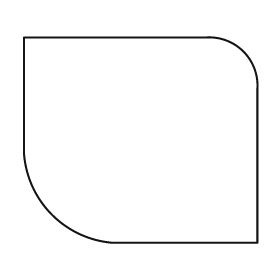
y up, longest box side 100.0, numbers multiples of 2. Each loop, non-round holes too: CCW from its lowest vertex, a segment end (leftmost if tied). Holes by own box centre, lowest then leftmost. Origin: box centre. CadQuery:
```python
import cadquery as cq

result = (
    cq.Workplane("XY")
    .moveTo(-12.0, -44.0)
    .lineTo(50.0, -44.0)
    .lineTo(50.0, 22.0)
    .threePointArc((44.0, 38.0), (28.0, 44.0))
    .lineTo(-50.0, 44.0)
    .lineTo(-50.0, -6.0)
    .threePointArc((-38.0, -32.0), (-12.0, -44.0))
    .close()
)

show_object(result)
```